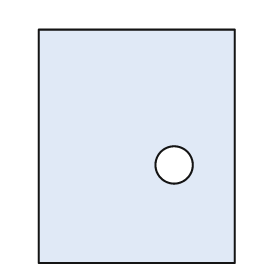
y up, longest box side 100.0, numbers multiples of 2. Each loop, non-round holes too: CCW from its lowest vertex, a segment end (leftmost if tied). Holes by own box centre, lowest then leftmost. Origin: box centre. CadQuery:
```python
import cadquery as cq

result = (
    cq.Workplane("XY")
    .moveTo(-42.0, -50.0)
    .lineTo(42.0, -50.0)
    .lineTo(42.0, 50.0)
    .lineTo(-42.0, 50.0)
    .close()
    .moveTo(16.0, -8.0)
    .circle(8.0)
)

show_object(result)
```